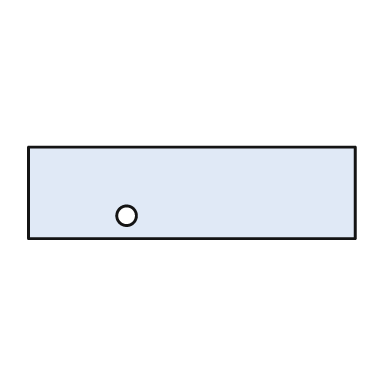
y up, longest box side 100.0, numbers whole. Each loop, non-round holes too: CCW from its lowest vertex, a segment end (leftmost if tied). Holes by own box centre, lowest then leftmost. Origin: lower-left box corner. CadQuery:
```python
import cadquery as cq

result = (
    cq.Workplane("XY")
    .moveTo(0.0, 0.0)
    .lineTo(100.0, 0.0)
    .lineTo(100.0, 28.0)
    .lineTo(0.0, 28.0)
    .close()
    .moveTo(30.0, 7.0)
    .circle(3.0)
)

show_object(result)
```